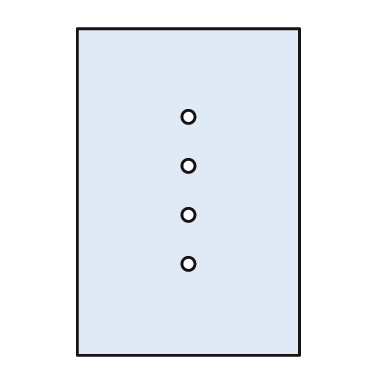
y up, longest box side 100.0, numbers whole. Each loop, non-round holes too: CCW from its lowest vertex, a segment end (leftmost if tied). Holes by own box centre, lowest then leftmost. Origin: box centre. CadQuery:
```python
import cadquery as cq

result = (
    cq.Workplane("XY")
    .moveTo(-34.0, -50.0)
    .lineTo(34.0, -50.0)
    .lineTo(34.0, 50.0)
    .lineTo(-34.0, 50.0)
    .close()
    .moveTo(0.0, -22.0)
    .circle(2.0)
    .moveTo(0.0, -7.0)
    .circle(2.0)
    .moveTo(0.0, 8.0)
    .circle(2.0)
    .moveTo(0.0, 23.0)
    .circle(2.0)
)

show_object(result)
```